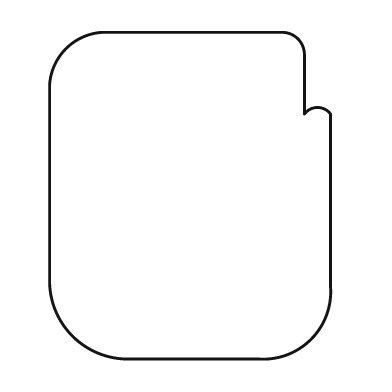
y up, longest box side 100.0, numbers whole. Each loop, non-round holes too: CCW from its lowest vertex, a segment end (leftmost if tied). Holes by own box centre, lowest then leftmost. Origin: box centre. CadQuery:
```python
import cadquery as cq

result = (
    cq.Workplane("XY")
    .moveTo(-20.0, -50.0)
    .lineTo(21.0, -50.0)
    .threePointArc((37.0, -44.0), (43.0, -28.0))
    .lineTo(43.0, 25.0)
    .threePointArc((39.0, 27.0), (35.0, 25.0))
    .lineTo(35.0, 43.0)
    .threePointArc((33.0, 48.0), (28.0, 50.0))
    .lineTo(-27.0, 50.0)
    .threePointArc((-38.0, 45.0), (-43.0, 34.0))
    .lineTo(-43.0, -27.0)
    .threePointArc((-36.0, -43.0), (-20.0, -50.0))
    .close()
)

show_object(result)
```